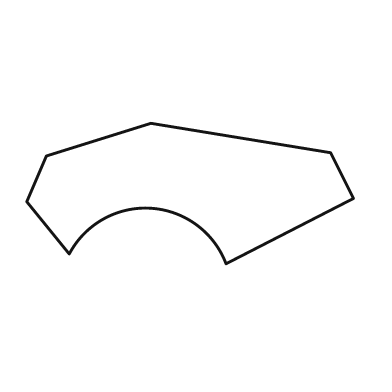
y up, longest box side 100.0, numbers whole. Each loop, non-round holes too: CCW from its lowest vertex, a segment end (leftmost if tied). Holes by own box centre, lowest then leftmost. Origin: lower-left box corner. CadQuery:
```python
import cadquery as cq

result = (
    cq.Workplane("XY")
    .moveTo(61.0, 0.0)
    .lineTo(100.0, 20.0)
    .lineTo(93.0, 34.0)
    .lineTo(38.0, 43.0)
    .lineTo(6.0, 33.0)
    .lineTo(0.0, 19.0)
    .lineTo(13.0, 3.0)
    .threePointArc((38.0, 17.0), (61.0, 0.0))
    .close()
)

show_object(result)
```